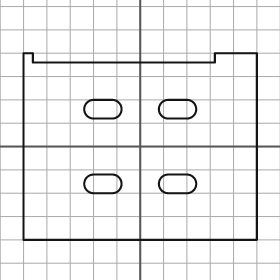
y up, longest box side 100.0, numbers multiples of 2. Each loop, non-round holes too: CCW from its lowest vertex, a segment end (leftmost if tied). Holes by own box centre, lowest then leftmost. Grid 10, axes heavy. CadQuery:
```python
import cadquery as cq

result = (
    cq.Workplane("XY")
    .moveTo(-50.0, -40.0)
    .lineTo(50.0, -40.0)
    .lineTo(50.0, 40.0)
    .lineTo(32.0, 40.0)
    .lineTo(32.0, 36.0)
    .lineTo(-46.0, 36.0)
    .lineTo(-46.0, 40.0)
    .lineTo(-50.0, 40.0)
    .close()
    .moveTo(-20.0, -20.0)
    .lineTo(-12.0, -20.0)
    .threePointArc((-8.0, -16.0), (-12.0, -12.0))
    .lineTo(-20.0, -12.0)
    .threePointArc((-24.0, -16.0), (-20.0, -20.0))
    .close()
    .moveTo(12.0, -20.0)
    .lineTo(20.0, -20.0)
    .threePointArc((24.0, -16.0), (20.0, -12.0))
    .lineTo(12.0, -12.0)
    .threePointArc((8.0, -16.0), (12.0, -20.0))
    .close()
    .moveTo(-20.0, 12.0)
    .lineTo(-12.0, 12.0)
    .threePointArc((-8.0, 16.0), (-12.0, 20.0))
    .lineTo(-20.0, 20.0)
    .threePointArc((-24.0, 16.0), (-20.0, 12.0))
    .close()
    .moveTo(12.0, 12.0)
    .lineTo(20.0, 12.0)
    .threePointArc((24.0, 16.0), (20.0, 20.0))
    .lineTo(12.0, 20.0)
    .threePointArc((8.0, 16.0), (12.0, 12.0))
    .close()
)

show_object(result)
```